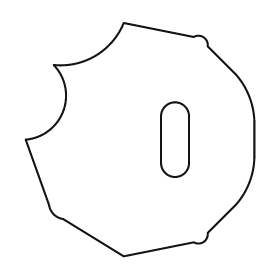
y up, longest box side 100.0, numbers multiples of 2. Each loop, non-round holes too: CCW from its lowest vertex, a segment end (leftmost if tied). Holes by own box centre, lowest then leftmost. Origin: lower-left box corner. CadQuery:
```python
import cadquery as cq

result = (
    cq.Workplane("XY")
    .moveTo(42.0, 0.0)
    .lineTo(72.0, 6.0)
    .threePointArc((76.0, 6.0), (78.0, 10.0))
    .lineTo(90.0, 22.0)
    .threePointArc((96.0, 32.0), (98.0, 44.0))
    .lineTo(98.0, 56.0)
    .threePointArc((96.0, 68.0), (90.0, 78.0))
    .lineTo(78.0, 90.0)
    .threePointArc((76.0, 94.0), (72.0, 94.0))
    .lineTo(42.0, 100.0)
    .threePointArc((30.0, 86.0), (12.0, 82.0))
    .threePointArc((16.0, 62.0), (0.0, 50.0))
    .lineTo(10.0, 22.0)
    .threePointArc((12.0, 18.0), (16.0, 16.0))
    .close()
    .moveTo(58.0, 40.0)
    .threePointArc((64.0, 34.0), (70.0, 40.0))
    .lineTo(70.0, 60.0)
    .threePointArc((64.0, 66.0), (58.0, 60.0))
    .close()
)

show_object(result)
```